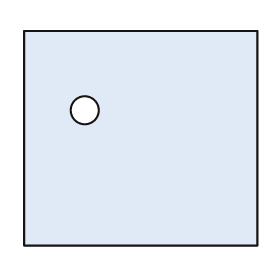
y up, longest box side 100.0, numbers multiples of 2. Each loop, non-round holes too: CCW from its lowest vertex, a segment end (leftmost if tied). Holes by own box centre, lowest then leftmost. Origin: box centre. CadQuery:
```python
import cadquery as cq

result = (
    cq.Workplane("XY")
    .moveTo(-50.0, -46.0)
    .lineTo(50.0, -46.0)
    .lineTo(50.0, 46.0)
    .lineTo(-50.0, 46.0)
    .close()
    .moveTo(-24.0, 12.0)
    .circle(6.0)
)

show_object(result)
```